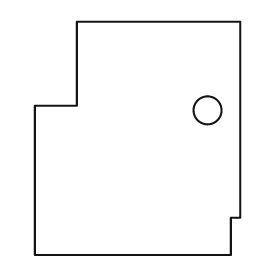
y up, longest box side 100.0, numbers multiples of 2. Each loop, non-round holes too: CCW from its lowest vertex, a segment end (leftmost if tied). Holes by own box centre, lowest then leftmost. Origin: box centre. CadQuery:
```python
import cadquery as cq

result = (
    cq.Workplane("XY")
    .moveTo(-44.0, -50.0)
    .lineTo(40.0, -50.0)
    .lineTo(40.0, -34.0)
    .lineTo(44.0, -34.0)
    .lineTo(44.0, 50.0)
    .lineTo(-26.0, 50.0)
    .lineTo(-26.0, 14.0)
    .lineTo(-44.0, 14.0)
    .close()
    .moveTo(30.0, 12.0)
    .circle(6.0)
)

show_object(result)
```